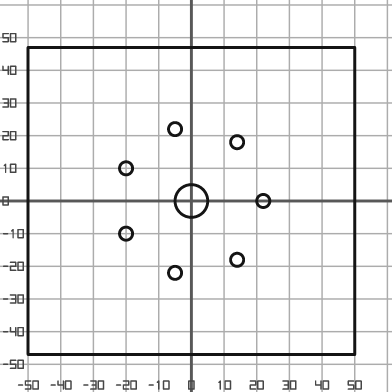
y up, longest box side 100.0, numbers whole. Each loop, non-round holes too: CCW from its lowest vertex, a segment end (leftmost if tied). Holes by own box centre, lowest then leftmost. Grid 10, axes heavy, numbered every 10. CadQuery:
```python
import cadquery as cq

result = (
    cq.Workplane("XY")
    .moveTo(-50.0, -47.0)
    .lineTo(50.0, -47.0)
    .lineTo(50.0, 47.0)
    .lineTo(-50.0, 47.0)
    .close()
    .moveTo(-5.0, -22.0)
    .circle(2.0)
    .moveTo(14.0, -18.0)
    .circle(2.0)
    .moveTo(-20.0, -10.0)
    .circle(2.0)
    .moveTo(0.0, 0.0)
    .circle(5.0)
    .moveTo(22.0, 0.0)
    .circle(2.0)
    .moveTo(-20.0, 10.0)
    .circle(2.0)
    .moveTo(14.0, 18.0)
    .circle(2.0)
    .moveTo(-5.0, 22.0)
    .circle(2.0)
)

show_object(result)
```